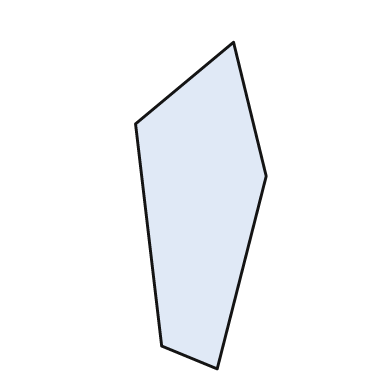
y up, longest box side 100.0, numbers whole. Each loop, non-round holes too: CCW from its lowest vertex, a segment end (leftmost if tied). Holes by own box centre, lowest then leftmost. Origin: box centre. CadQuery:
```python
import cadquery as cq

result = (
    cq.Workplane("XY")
    .moveTo(5.0, -50.0)
    .lineTo(20.0, 9.0)
    .lineTo(10.0, 50.0)
    .lineTo(-20.0, 25.0)
    .lineTo(-12.0, -43.0)
    .close()
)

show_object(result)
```